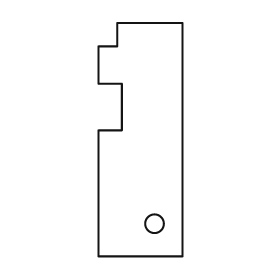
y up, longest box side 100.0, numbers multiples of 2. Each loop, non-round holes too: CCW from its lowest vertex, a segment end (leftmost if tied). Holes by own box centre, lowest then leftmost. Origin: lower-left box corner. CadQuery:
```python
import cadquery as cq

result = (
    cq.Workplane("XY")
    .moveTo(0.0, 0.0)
    .lineTo(36.0, 0.0)
    .lineTo(36.0, 100.0)
    .lineTo(8.0, 100.0)
    .lineTo(8.0, 90.0)
    .lineTo(0.0, 90.0)
    .lineTo(0.0, 74.0)
    .lineTo(10.0, 74.0)
    .lineTo(10.0, 54.0)
    .lineTo(0.0, 54.0)
    .close()
    .moveTo(24.0, 14.0)
    .circle(4.0)
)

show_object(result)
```